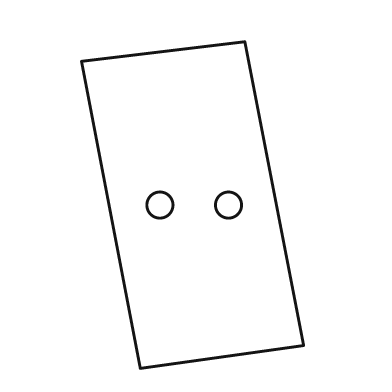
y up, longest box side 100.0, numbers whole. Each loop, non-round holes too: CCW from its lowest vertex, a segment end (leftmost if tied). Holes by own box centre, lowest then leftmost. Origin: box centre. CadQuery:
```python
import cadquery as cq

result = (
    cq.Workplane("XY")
    .moveTo(-16.0, -50.0)
    .lineTo(34.0, -43.0)
    .lineTo(16.0, 50.0)
    .lineTo(-34.0, 44.0)
    .close()
    .moveTo(-10.0, 0.0)
    .circle(4.0)
    .moveTo(11.0, 0.0)
    .circle(4.0)
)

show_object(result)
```